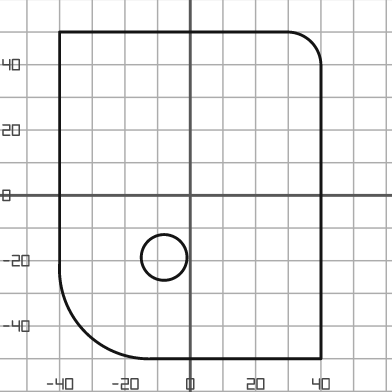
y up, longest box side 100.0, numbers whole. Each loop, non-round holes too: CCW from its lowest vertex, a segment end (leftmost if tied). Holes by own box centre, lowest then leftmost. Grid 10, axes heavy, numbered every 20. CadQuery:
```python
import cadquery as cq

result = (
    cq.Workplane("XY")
    .moveTo(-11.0, -50.0)
    .lineTo(40.0, -50.0)
    .lineTo(40.0, 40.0)
    .threePointArc((37.0, 47.0), (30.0, 50.0))
    .lineTo(-40.0, 50.0)
    .lineTo(-40.0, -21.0)
    .threePointArc((-32.0, -42.0), (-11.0, -50.0))
    .close()
    .moveTo(-8.0, -19.0)
    .circle(7.0)
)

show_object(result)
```